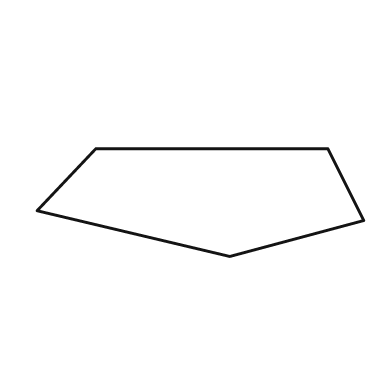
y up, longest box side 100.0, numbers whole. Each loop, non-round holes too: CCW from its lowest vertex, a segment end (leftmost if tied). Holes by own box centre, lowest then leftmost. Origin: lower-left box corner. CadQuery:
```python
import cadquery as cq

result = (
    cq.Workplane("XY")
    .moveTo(59.0, 0.0)
    .lineTo(100.0, 11.0)
    .lineTo(89.0, 33.0)
    .lineTo(18.0, 33.0)
    .lineTo(0.0, 14.0)
    .close()
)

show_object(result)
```